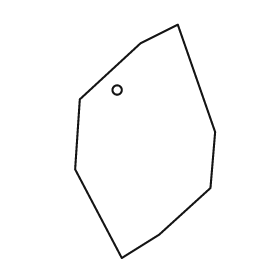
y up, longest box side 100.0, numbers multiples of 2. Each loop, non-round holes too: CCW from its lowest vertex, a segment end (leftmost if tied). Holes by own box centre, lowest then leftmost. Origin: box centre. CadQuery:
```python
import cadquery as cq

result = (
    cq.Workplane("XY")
    .moveTo(-10.0, -50.0)
    .lineTo(6.0, -40.0)
    .lineTo(28.0, -20.0)
    .lineTo(30.0, 4.0)
    .lineTo(14.0, 50.0)
    .lineTo(-2.0, 42.0)
    .lineTo(-28.0, 18.0)
    .lineTo(-30.0, -12.0)
    .close()
    .moveTo(-12.0, 22.0)
    .circle(2.0)
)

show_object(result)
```